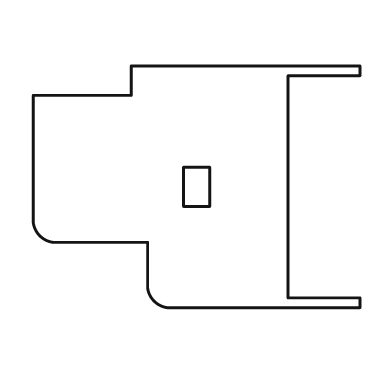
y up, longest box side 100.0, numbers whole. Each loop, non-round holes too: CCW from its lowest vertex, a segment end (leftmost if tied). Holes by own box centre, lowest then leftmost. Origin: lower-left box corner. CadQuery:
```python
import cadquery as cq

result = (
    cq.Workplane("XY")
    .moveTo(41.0, 0.0)
    .lineTo(100.0, 0.0)
    .lineTo(100.0, 3.0)
    .lineTo(78.0, 3.0)
    .lineTo(78.0, 71.0)
    .lineTo(100.0, 71.0)
    .lineTo(100.0, 74.0)
    .lineTo(30.0, 74.0)
    .lineTo(30.0, 65.0)
    .lineTo(0.0, 65.0)
    .lineTo(0.0, 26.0)
    .threePointArc((2.0, 22.0), (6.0, 20.0))
    .lineTo(35.0, 20.0)
    .lineTo(35.0, 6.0)
    .threePointArc((37.0, 2.0), (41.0, 0.0))
    .close()
    .moveTo(46.0, 31.0)
    .lineTo(54.0, 31.0)
    .lineTo(54.0, 43.0)
    .lineTo(46.0, 43.0)
    .close()
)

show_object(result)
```